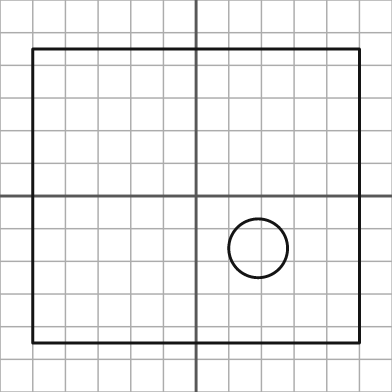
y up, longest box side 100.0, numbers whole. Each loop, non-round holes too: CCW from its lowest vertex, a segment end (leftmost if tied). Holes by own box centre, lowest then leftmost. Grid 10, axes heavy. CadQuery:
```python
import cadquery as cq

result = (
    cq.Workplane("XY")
    .moveTo(-50.0, -45.0)
    .lineTo(50.0, -45.0)
    .lineTo(50.0, 45.0)
    .lineTo(-50.0, 45.0)
    .close()
    .moveTo(19.0, -16.0)
    .circle(9.0)
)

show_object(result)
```